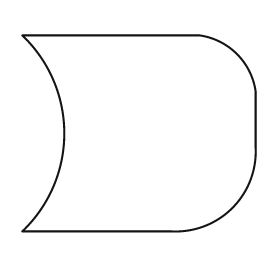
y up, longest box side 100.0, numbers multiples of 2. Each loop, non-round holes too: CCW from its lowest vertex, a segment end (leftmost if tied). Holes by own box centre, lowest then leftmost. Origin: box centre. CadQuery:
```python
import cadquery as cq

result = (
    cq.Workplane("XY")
    .moveTo(-50.0, -42.0)
    .lineTo(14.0, -42.0)
    .threePointArc((40.0, -32.0), (50.0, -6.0))
    .lineTo(50.0, 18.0)
    .threePointArc((42.0, 34.0), (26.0, 42.0))
    .lineTo(-50.0, 42.0)
    .threePointArc((-32.0, 0.0), (-50.0, -42.0))
    .close()
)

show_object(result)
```